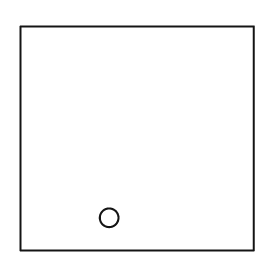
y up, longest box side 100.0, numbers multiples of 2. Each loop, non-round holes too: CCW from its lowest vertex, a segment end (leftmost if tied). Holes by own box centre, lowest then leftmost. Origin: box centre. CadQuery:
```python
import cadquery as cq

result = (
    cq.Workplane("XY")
    .moveTo(-50.0, -48.0)
    .lineTo(50.0, -48.0)
    .lineTo(50.0, 48.0)
    .lineTo(-50.0, 48.0)
    .close()
    .moveTo(-12.0, -34.0)
    .circle(4.0)
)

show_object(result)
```